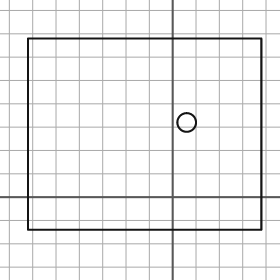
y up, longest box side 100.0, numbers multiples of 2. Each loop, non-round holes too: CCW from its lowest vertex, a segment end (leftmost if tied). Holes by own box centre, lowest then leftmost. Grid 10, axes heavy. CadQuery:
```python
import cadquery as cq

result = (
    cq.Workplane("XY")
    .moveTo(-62.0, -14.0)
    .lineTo(38.0, -14.0)
    .lineTo(38.0, 68.0)
    .lineTo(-62.0, 68.0)
    .close()
    .moveTo(6.0, 32.0)
    .circle(4.0)
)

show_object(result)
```